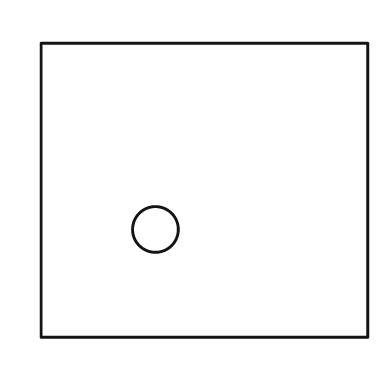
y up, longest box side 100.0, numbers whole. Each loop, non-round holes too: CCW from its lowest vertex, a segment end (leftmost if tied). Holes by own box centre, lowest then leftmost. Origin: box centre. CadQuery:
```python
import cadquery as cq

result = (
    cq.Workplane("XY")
    .moveTo(-50.0, -45.0)
    .lineTo(50.0, -45.0)
    .lineTo(50.0, 45.0)
    .lineTo(-50.0, 45.0)
    .close()
    .moveTo(-15.0, -12.0)
    .circle(7.0)
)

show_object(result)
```